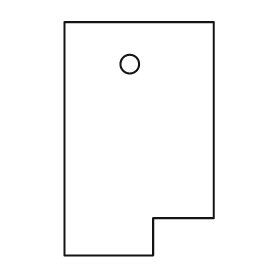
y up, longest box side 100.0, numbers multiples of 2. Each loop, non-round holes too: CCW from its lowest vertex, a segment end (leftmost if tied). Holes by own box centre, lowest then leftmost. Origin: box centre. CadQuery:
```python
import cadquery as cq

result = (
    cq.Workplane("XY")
    .moveTo(-32.0, -50.0)
    .lineTo(6.0, -50.0)
    .lineTo(6.0, -34.0)
    .lineTo(32.0, -34.0)
    .lineTo(32.0, 50.0)
    .lineTo(-32.0, 50.0)
    .close()
    .moveTo(-4.0, 32.0)
    .circle(4.0)
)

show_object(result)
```